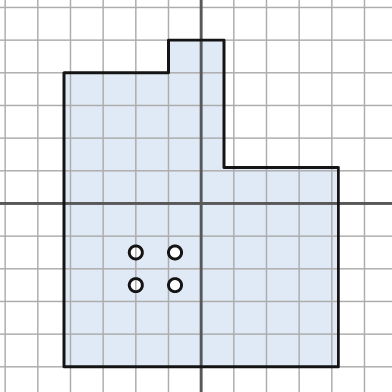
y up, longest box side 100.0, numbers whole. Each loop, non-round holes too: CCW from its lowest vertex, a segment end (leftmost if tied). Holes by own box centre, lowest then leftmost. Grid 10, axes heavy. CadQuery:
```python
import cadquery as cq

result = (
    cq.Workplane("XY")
    .moveTo(-42.0, -50.0)
    .lineTo(42.0, -50.0)
    .lineTo(42.0, 11.0)
    .lineTo(7.0, 11.0)
    .lineTo(7.0, 50.0)
    .lineTo(-10.0, 50.0)
    .lineTo(-10.0, 40.0)
    .lineTo(-42.0, 40.0)
    .close()
    .moveTo(-20.0, -25.0)
    .circle(2.0)
    .moveTo(-8.0, -25.0)
    .circle(2.0)
    .moveTo(-20.0, -15.0)
    .circle(2.0)
    .moveTo(-8.0, -15.0)
    .circle(2.0)
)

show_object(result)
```